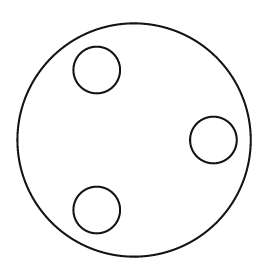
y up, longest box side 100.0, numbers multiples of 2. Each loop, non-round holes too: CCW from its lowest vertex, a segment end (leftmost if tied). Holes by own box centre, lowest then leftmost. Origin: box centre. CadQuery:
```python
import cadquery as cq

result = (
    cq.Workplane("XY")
    .moveTo(0.0, 0.0)
    .circle(50.0)
    .moveTo(-16.0, -30.0)
    .circle(10.0)
    .moveTo(34.0, 0.0)
    .circle(10.0)
    .moveTo(-16.0, 30.0)
    .circle(10.0)
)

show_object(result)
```